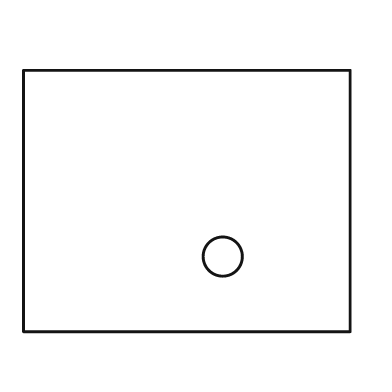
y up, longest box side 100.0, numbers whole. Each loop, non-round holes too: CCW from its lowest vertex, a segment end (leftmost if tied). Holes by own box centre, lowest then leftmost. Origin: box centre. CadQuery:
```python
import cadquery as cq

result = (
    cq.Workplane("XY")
    .moveTo(-50.0, -40.0)
    .lineTo(50.0, -40.0)
    .lineTo(50.0, 40.0)
    .lineTo(-50.0, 40.0)
    .close()
    .moveTo(11.0, -17.0)
    .circle(6.0)
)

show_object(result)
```